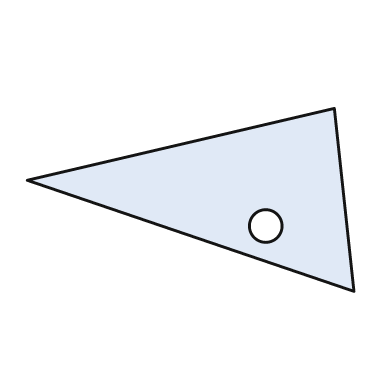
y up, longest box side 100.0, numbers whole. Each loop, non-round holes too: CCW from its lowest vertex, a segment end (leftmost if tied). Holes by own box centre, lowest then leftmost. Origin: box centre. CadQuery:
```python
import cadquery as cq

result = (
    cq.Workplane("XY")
    .moveTo(50.0, -28.0)
    .lineTo(44.0, 28.0)
    .lineTo(-50.0, 6.0)
    .close()
    .moveTo(23.0, -8.0)
    .circle(5.0)
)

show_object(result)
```